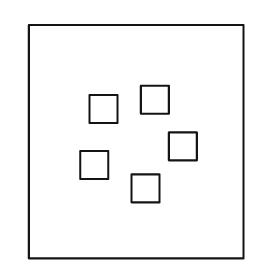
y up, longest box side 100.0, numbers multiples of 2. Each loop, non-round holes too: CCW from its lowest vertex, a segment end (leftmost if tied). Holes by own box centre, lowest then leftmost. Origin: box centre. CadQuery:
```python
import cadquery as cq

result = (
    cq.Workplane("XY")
    .moveTo(-46.0, -50.0)
    .lineTo(46.0, -50.0)
    .lineTo(46.0, 50.0)
    .lineTo(-46.0, 50.0)
    .close()
    .moveTo(-2.0, -26.0)
    .lineTo(10.0, -26.0)
    .lineTo(10.0, -14.0)
    .lineTo(-2.0, -14.0)
    .close()
    .moveTo(-24.0, -16.0)
    .lineTo(-12.0, -16.0)
    .lineTo(-12.0, -4.0)
    .lineTo(-24.0, -4.0)
    .close()
    .moveTo(14.0, -8.0)
    .lineTo(26.0, -8.0)
    .lineTo(26.0, 4.0)
    .lineTo(14.0, 4.0)
    .close()
    .moveTo(-20.0, 8.0)
    .lineTo(-8.0, 8.0)
    .lineTo(-8.0, 20.0)
    .lineTo(-20.0, 20.0)
    .close()
    .moveTo(2.0, 12.0)
    .lineTo(14.0, 12.0)
    .lineTo(14.0, 24.0)
    .lineTo(2.0, 24.0)
    .close()
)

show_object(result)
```